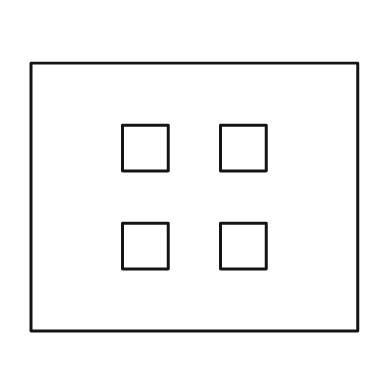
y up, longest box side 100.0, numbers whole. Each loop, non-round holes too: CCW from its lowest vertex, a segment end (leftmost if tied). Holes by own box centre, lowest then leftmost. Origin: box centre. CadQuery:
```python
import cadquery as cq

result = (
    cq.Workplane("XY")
    .moveTo(-50.0, -41.0)
    .lineTo(50.0, -41.0)
    .lineTo(50.0, 41.0)
    .lineTo(-50.0, 41.0)
    .close()
    .moveTo(-22.0, -22.0)
    .lineTo(-8.0, -22.0)
    .lineTo(-8.0, -8.0)
    .lineTo(-22.0, -8.0)
    .close()
    .moveTo(8.0, -22.0)
    .lineTo(22.0, -22.0)
    .lineTo(22.0, -8.0)
    .lineTo(8.0, -8.0)
    .close()
    .moveTo(-22.0, 8.0)
    .lineTo(-8.0, 8.0)
    .lineTo(-8.0, 22.0)
    .lineTo(-22.0, 22.0)
    .close()
    .moveTo(8.0, 8.0)
    .lineTo(22.0, 8.0)
    .lineTo(22.0, 22.0)
    .lineTo(8.0, 22.0)
    .close()
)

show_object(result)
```